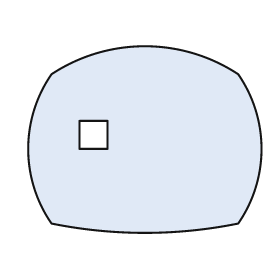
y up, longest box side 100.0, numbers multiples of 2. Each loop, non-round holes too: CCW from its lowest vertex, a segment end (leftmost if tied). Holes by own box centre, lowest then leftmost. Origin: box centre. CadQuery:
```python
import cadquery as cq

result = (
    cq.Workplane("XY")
    .moveTo(-40.0, -36.0)
    .threePointArc((0.0, -40.0), (40.0, -36.0))
    .threePointArc((50.0, -4.0), (40.0, 28.0))
    .threePointArc((0.0, 40.0), (-40.0, 28.0))
    .threePointArc((-50.0, -4.0), (-40.0, -36.0))
    .close()
    .moveTo(-28.0, -4.0)
    .lineTo(-16.0, -4.0)
    .lineTo(-16.0, 8.0)
    .lineTo(-28.0, 8.0)
    .close()
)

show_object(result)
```